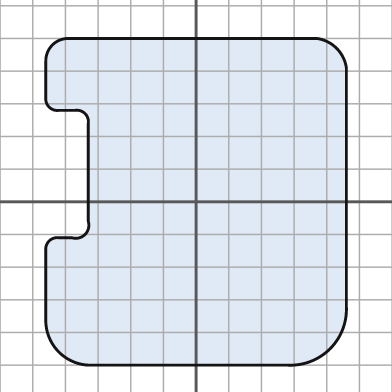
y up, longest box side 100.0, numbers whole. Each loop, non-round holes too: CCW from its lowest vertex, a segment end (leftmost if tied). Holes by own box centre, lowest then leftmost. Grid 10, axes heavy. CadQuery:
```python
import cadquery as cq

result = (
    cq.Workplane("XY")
    .moveTo(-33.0, -50.0)
    .lineTo(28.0, -50.0)
    .threePointArc((41.0, -45.0), (46.0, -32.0))
    .lineTo(46.0, 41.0)
    .threePointArc((43.0, 47.0), (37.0, 50.0))
    .lineTo(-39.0, 50.0)
    .threePointArc((-44.0, 48.0), (-46.0, 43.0))
    .lineTo(-46.0, 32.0)
    .threePointArc((-45.0, 29.0), (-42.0, 28.0))
    .lineTo(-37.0, 28.0)
    .threePointArc((-34.0, 27.0), (-33.0, 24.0))
    .lineTo(-33.0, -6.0)
    .threePointArc((-34.0, -10.0), (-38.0, -11.0))
    .lineTo(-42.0, -11.0)
    .threePointArc((-45.0, -12.0), (-46.0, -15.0))
    .lineTo(-46.0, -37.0)
    .threePointArc((-42.0, -46.0), (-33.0, -50.0))
    .close()
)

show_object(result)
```